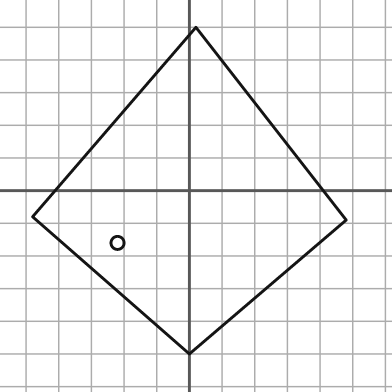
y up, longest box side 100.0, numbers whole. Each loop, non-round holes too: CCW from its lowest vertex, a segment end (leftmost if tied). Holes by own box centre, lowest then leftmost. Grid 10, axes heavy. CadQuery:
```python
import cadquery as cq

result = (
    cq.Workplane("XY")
    .moveTo(0.0, -50.0)
    .lineTo(48.0, -9.0)
    .lineTo(2.0, 50.0)
    .lineTo(-48.0, -8.0)
    .close()
    .moveTo(-22.0, -16.0)
    .circle(2.0)
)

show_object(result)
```